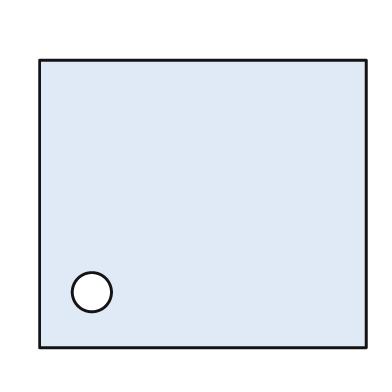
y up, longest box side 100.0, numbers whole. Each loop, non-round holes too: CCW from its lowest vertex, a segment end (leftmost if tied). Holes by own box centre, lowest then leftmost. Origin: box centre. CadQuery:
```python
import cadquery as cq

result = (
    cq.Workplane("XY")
    .moveTo(-50.0, -44.0)
    .lineTo(50.0, -44.0)
    .lineTo(50.0, 44.0)
    .lineTo(-50.0, 44.0)
    .close()
    .moveTo(-34.0, -27.0)
    .circle(6.0)
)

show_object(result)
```